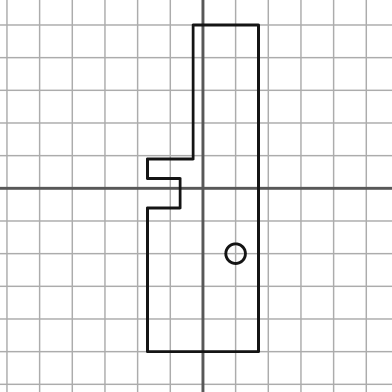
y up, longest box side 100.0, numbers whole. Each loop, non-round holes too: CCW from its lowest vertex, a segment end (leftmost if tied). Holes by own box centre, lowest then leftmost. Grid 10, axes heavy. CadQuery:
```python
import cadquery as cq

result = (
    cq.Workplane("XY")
    .moveTo(-17.0, -50.0)
    .lineTo(17.0, -50.0)
    .lineTo(17.0, 50.0)
    .lineTo(-3.0, 50.0)
    .lineTo(-3.0, 9.0)
    .lineTo(-17.0, 9.0)
    .lineTo(-17.0, 3.0)
    .lineTo(-7.0, 3.0)
    .lineTo(-7.0, -6.0)
    .lineTo(-17.0, -6.0)
    .close()
    .moveTo(10.0, -20.0)
    .circle(3.0)
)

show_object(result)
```